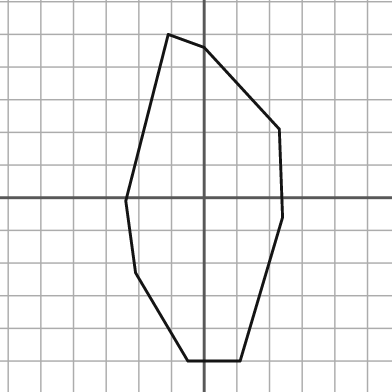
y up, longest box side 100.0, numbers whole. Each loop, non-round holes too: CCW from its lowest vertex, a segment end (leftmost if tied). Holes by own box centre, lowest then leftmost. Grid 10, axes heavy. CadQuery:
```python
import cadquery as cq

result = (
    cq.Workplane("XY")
    .moveTo(-5.0, -50.0)
    .lineTo(11.0, -50.0)
    .lineTo(24.0, -6.0)
    .lineTo(23.0, 21.0)
    .lineTo(0.0, 46.0)
    .lineTo(-11.0, 50.0)
    .lineTo(-24.0, -1.0)
    .lineTo(-21.0, -23.0)
    .close()
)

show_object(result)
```